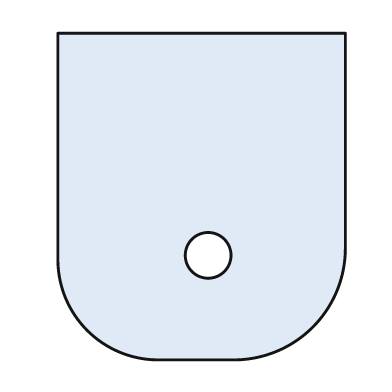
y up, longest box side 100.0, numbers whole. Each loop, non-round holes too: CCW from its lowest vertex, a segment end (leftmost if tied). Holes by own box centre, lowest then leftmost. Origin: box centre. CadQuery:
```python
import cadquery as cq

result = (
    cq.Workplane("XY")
    .moveTo(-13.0, -50.0)
    .lineTo(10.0, -50.0)
    .threePointArc((34.0, -40.0), (44.0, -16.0))
    .lineTo(44.0, 50.0)
    .lineTo(-44.0, 50.0)
    .lineTo(-44.0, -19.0)
    .threePointArc((-35.0, -41.0), (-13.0, -50.0))
    .close()
    .moveTo(2.0, -18.0)
    .circle(7.0)
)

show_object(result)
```